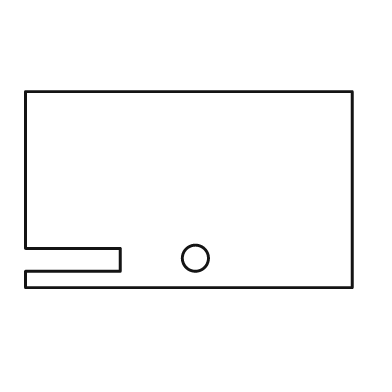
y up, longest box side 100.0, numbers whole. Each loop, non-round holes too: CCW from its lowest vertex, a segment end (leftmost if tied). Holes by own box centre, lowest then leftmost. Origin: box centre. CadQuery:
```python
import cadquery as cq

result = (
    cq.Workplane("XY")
    .moveTo(-50.0, -30.0)
    .lineTo(50.0, -30.0)
    .lineTo(50.0, 30.0)
    .lineTo(-50.0, 30.0)
    .lineTo(-50.0, -18.0)
    .lineTo(-21.0, -18.0)
    .lineTo(-21.0, -25.0)
    .lineTo(-50.0, -25.0)
    .close()
    .moveTo(2.0, -21.0)
    .circle(4.0)
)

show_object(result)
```